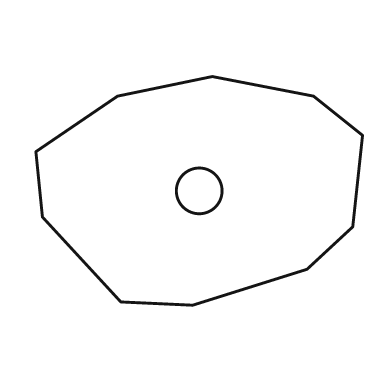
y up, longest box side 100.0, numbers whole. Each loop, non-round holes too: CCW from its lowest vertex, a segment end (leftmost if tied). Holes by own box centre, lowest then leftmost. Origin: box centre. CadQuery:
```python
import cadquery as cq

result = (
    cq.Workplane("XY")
    .moveTo(-2.0, -35.0)
    .lineTo(33.0, -24.0)
    .lineTo(47.0, -11.0)
    .lineTo(50.0, 17.0)
    .lineTo(35.0, 29.0)
    .lineTo(4.0, 35.0)
    .lineTo(-25.0, 29.0)
    .lineTo(-50.0, 12.0)
    .lineTo(-48.0, -8.0)
    .lineTo(-24.0, -34.0)
    .close()
    .moveTo(0.0, 0.0)
    .circle(7.0)
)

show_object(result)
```